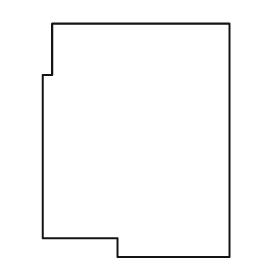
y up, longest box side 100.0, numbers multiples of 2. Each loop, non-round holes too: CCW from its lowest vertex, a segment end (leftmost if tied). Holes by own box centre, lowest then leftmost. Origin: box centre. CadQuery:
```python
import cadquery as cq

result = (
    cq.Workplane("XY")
    .moveTo(-8.0, -50.0)
    .lineTo(40.0, -50.0)
    .lineTo(40.0, 50.0)
    .lineTo(-36.0, 50.0)
    .lineTo(-36.0, 28.0)
    .lineTo(-40.0, 28.0)
    .lineTo(-40.0, -42.0)
    .lineTo(-8.0, -42.0)
    .close()
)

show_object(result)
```